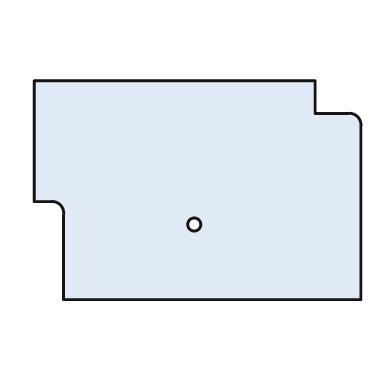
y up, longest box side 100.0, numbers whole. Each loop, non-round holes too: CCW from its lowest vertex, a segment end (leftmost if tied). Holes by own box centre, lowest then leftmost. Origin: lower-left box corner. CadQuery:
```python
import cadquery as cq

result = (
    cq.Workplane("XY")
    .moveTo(9.0, 0.0)
    .lineTo(100.0, 0.0)
    .lineTo(100.0, 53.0)
    .threePointArc((99.0, 56.0), (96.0, 57.0))
    .lineTo(86.0, 57.0)
    .lineTo(86.0, 67.0)
    .lineTo(0.0, 67.0)
    .lineTo(0.0, 30.0)
    .lineTo(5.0, 30.0)
    .threePointArc((8.0, 29.0), (9.0, 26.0))
    .close()
    .moveTo(49.0, 23.0)
    .circle(2.0)
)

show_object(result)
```